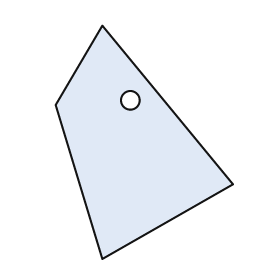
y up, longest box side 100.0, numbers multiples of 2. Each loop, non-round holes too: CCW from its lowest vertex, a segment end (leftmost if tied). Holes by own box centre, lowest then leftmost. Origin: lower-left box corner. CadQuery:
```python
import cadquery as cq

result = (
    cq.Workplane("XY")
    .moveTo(20.0, 0.0)
    .lineTo(76.0, 32.0)
    .lineTo(20.0, 100.0)
    .lineTo(0.0, 66.0)
    .close()
    .moveTo(32.0, 68.0)
    .circle(4.0)
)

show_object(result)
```